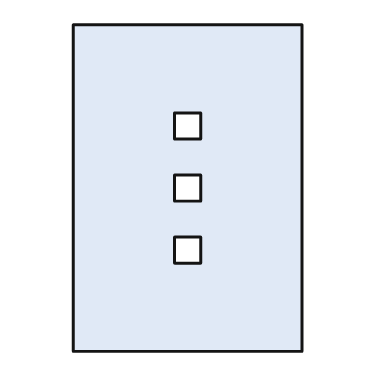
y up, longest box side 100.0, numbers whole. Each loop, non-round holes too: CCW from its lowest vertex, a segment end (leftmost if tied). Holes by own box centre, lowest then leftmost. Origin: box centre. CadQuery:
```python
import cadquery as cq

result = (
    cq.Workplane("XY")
    .moveTo(-35.0, -50.0)
    .lineTo(35.0, -50.0)
    .lineTo(35.0, 50.0)
    .lineTo(-35.0, 50.0)
    .close()
    .moveTo(-4.0, -23.0)
    .lineTo(4.0, -23.0)
    .lineTo(4.0, -15.0)
    .lineTo(-4.0, -15.0)
    .close()
    .moveTo(-4.0, -4.0)
    .lineTo(4.0, -4.0)
    .lineTo(4.0, 4.0)
    .lineTo(-4.0, 4.0)
    .close()
    .moveTo(-4.0, 15.0)
    .lineTo(4.0, 15.0)
    .lineTo(4.0, 23.0)
    .lineTo(-4.0, 23.0)
    .close()
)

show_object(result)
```